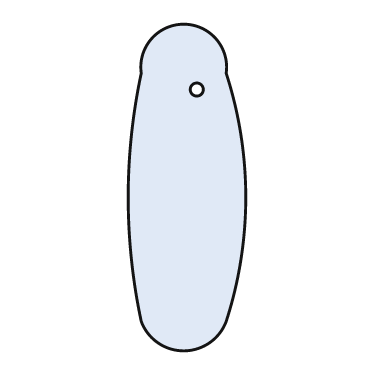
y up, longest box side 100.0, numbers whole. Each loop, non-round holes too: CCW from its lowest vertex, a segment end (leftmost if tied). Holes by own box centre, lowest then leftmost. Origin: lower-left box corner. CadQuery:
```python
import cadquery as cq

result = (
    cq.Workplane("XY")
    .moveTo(4.0, 9.0)
    .threePointArc((17.0, 0.0), (30.0, 9.0))
    .threePointArc((36.0, 47.0), (30.0, 85.0))
    .threePointArc((17.0, 100.0), (4.0, 85.0))
    .threePointArc((0.0, 47.0), (4.0, 9.0))
    .close()
    .moveTo(21.0, 80.0)
    .circle(2.0)
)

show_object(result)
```